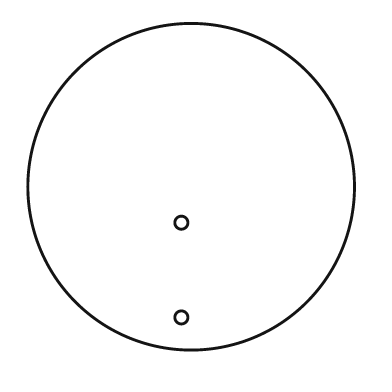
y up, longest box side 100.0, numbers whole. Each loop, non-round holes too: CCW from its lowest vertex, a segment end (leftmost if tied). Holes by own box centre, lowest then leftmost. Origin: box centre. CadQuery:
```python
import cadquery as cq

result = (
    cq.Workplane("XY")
    .moveTo(0.0, 0.0)
    .circle(50.0)
    .moveTo(-3.0, -40.0)
    .circle(2.0)
    .moveTo(-3.0, -11.0)
    .circle(2.0)
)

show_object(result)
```